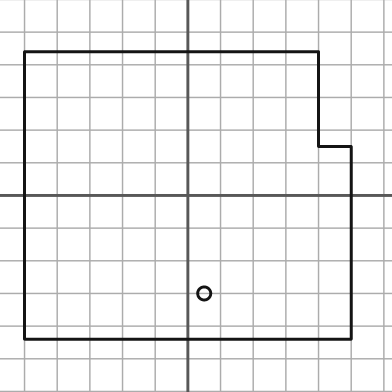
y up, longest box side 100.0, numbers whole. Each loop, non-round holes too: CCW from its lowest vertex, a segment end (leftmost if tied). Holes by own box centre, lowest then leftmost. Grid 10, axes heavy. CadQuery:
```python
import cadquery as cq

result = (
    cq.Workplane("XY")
    .moveTo(-50.0, -44.0)
    .lineTo(50.0, -44.0)
    .lineTo(50.0, 15.0)
    .lineTo(40.0, 15.0)
    .lineTo(40.0, 44.0)
    .lineTo(-50.0, 44.0)
    .close()
    .moveTo(5.0, -30.0)
    .circle(2.0)
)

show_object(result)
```